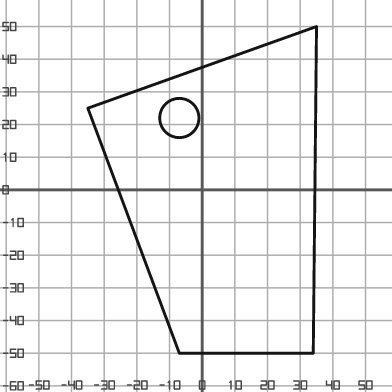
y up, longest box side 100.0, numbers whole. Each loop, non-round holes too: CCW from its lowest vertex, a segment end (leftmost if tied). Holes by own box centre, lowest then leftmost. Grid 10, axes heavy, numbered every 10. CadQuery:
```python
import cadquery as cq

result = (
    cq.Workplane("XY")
    .moveTo(-7.0, -50.0)
    .lineTo(34.0, -50.0)
    .lineTo(35.0, 50.0)
    .lineTo(-35.0, 25.0)
    .close()
    .moveTo(-7.0, 22.0)
    .circle(6.0)
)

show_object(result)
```